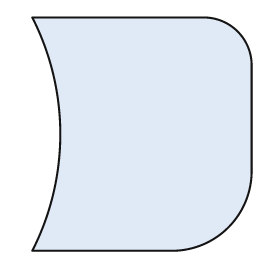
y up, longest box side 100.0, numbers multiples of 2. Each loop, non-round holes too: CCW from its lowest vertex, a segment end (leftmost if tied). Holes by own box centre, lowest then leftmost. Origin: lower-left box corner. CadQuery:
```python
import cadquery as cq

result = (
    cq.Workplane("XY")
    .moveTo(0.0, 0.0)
    .lineTo(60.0, 0.0)
    .threePointArc((84.0, 10.0), (94.0, 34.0))
    .lineTo(94.0, 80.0)
    .threePointArc((88.0, 94.0), (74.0, 100.0))
    .lineTo(0.0, 100.0)
    .threePointArc((12.0, 50.0), (0.0, 0.0))
    .close()
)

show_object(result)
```